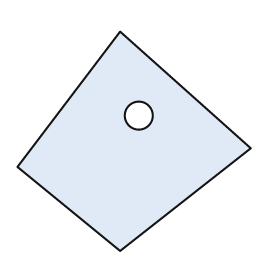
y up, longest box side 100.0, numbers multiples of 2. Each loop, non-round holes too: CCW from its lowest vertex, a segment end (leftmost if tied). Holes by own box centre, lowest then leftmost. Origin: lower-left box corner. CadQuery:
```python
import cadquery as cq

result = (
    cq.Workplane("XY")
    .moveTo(44.0, 0.0)
    .lineTo(100.0, 44.0)
    .lineTo(44.0, 94.0)
    .lineTo(0.0, 36.0)
    .close()
    .moveTo(52.0, 58.0)
    .circle(6.0)
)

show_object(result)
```